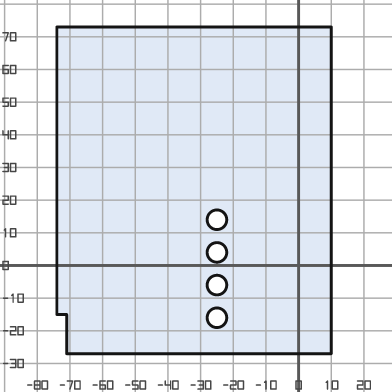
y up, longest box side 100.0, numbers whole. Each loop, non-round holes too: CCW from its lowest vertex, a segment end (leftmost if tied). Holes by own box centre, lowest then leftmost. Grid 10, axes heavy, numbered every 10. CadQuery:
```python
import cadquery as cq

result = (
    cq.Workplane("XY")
    .moveTo(-71.0, -27.0)
    .lineTo(10.0, -27.0)
    .lineTo(10.0, 73.0)
    .lineTo(-74.0, 73.0)
    .lineTo(-74.0, -15.0)
    .lineTo(-71.0, -15.0)
    .close()
    .moveTo(-25.0, -16.0)
    .circle(3.0)
    .moveTo(-25.0, -6.0)
    .circle(3.0)
    .moveTo(-25.0, 4.0)
    .circle(3.0)
    .moveTo(-25.0, 14.0)
    .circle(3.0)
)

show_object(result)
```